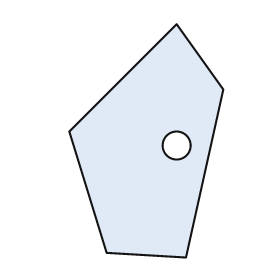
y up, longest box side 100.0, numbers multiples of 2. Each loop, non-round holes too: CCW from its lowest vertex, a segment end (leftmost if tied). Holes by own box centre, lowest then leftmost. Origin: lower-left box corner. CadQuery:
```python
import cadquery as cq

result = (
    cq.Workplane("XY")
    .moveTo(50.0, 0.0)
    .lineTo(66.0, 72.0)
    .lineTo(46.0, 100.0)
    .lineTo(0.0, 54.0)
    .lineTo(16.0, 2.0)
    .close()
    .moveTo(46.0, 48.0)
    .circle(6.0)
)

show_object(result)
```